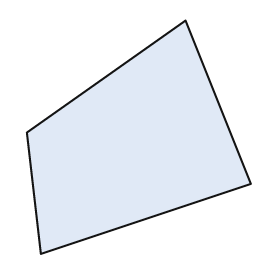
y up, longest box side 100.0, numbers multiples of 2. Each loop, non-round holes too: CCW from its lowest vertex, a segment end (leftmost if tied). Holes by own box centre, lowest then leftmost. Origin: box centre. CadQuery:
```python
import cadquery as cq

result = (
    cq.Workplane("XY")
    .moveTo(-42.0, -50.0)
    .lineTo(48.0, -20.0)
    .lineTo(20.0, 50.0)
    .lineTo(-48.0, 2.0)
    .close()
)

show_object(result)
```